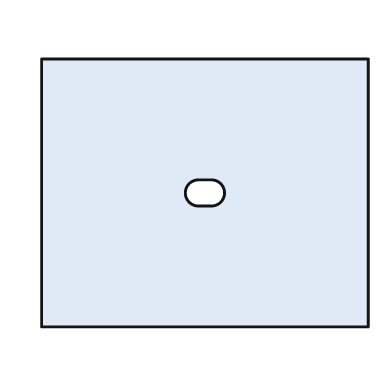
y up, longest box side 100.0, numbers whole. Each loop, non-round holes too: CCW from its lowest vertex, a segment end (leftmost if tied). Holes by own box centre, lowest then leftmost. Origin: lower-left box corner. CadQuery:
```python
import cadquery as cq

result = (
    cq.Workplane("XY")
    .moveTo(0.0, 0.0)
    .lineTo(100.0, 0.0)
    .lineTo(100.0, 82.0)
    .lineTo(0.0, 82.0)
    .close()
    .moveTo(48.0, 37.0)
    .lineTo(52.0, 37.0)
    .threePointArc((56.0, 41.0), (52.0, 45.0))
    .lineTo(48.0, 45.0)
    .threePointArc((44.0, 41.0), (48.0, 37.0))
    .close()
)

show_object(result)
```